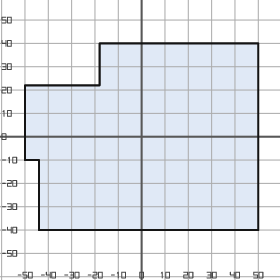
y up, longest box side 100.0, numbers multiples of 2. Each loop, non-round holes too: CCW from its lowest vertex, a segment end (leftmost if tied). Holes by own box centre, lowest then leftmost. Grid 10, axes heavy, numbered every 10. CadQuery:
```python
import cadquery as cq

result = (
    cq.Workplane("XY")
    .moveTo(-44.0, -40.0)
    .lineTo(50.0, -40.0)
    .lineTo(50.0, 40.0)
    .lineTo(-18.0, 40.0)
    .lineTo(-18.0, 22.0)
    .lineTo(-50.0, 22.0)
    .lineTo(-50.0, -10.0)
    .lineTo(-44.0, -10.0)
    .close()
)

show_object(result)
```